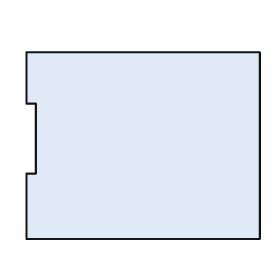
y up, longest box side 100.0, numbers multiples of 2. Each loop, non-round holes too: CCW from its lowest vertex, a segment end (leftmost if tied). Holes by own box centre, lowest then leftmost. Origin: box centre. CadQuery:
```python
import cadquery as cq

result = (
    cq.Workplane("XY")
    .moveTo(-50.0, -40.0)
    .lineTo(50.0, -40.0)
    .lineTo(50.0, 40.0)
    .lineTo(-50.0, 40.0)
    .lineTo(-50.0, 18.0)
    .lineTo(-46.0, 18.0)
    .lineTo(-46.0, -12.0)
    .lineTo(-50.0, -12.0)
    .close()
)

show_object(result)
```